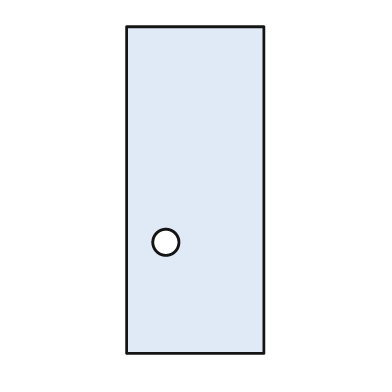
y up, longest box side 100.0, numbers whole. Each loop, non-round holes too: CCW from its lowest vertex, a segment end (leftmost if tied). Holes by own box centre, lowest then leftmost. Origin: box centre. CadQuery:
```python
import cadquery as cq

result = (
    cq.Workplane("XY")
    .moveTo(-21.0, -50.0)
    .lineTo(21.0, -50.0)
    .lineTo(21.0, 50.0)
    .lineTo(-21.0, 50.0)
    .close()
    .moveTo(-9.0, -16.0)
    .circle(4.0)
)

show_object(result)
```